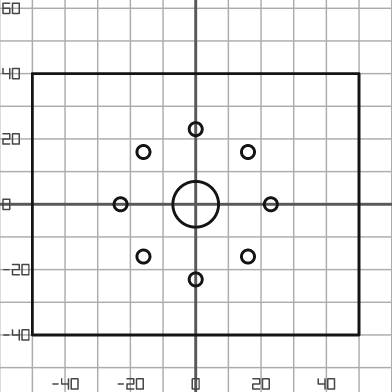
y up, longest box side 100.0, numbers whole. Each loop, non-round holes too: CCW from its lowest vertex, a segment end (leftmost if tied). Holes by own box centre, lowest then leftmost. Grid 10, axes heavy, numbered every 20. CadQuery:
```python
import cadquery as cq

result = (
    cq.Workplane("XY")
    .moveTo(-50.0, -40.0)
    .lineTo(50.0, -40.0)
    .lineTo(50.0, 40.0)
    .lineTo(-50.0, 40.0)
    .close()
    .moveTo(0.0, -23.0)
    .circle(2.0)
    .moveTo(-16.0, -16.0)
    .circle(2.0)
    .moveTo(16.0, -16.0)
    .circle(2.0)
    .moveTo(-23.0, 0.0)
    .circle(2.0)
    .moveTo(0.0, 0.0)
    .circle(7.0)
    .moveTo(23.0, 0.0)
    .circle(2.0)
    .moveTo(-16.0, 16.0)
    .circle(2.0)
    .moveTo(16.0, 16.0)
    .circle(2.0)
    .moveTo(0.0, 23.0)
    .circle(2.0)
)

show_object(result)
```